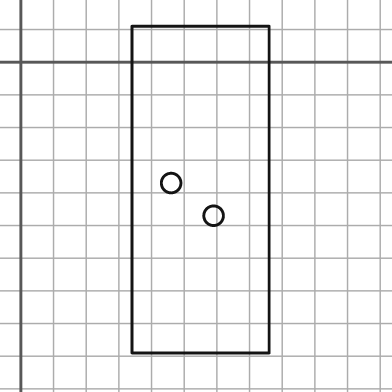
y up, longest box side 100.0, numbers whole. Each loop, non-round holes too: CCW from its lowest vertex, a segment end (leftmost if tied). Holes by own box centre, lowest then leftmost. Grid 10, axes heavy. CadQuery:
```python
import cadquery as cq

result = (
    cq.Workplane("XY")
    .moveTo(34.0, -89.0)
    .lineTo(76.0, -89.0)
    .lineTo(76.0, 11.0)
    .lineTo(34.0, 11.0)
    .close()
    .moveTo(59.0, -47.0)
    .circle(3.0)
    .moveTo(46.0, -37.0)
    .circle(3.0)
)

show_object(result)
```